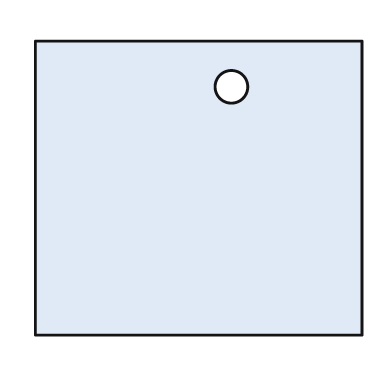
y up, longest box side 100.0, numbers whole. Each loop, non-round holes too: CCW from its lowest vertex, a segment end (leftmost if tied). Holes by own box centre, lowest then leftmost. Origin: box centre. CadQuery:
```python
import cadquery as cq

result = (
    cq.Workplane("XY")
    .moveTo(-50.0, -45.0)
    .lineTo(50.0, -45.0)
    .lineTo(50.0, 45.0)
    .lineTo(-50.0, 45.0)
    .close()
    .moveTo(10.0, 31.0)
    .circle(5.0)
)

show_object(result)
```